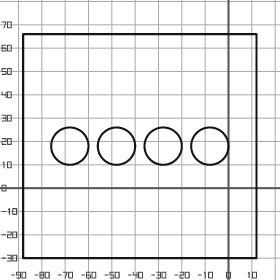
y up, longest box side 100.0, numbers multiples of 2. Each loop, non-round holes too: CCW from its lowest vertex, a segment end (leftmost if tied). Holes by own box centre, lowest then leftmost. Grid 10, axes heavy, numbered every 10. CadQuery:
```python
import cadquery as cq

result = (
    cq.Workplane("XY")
    .moveTo(-88.0, -30.0)
    .lineTo(12.0, -30.0)
    .lineTo(12.0, 66.0)
    .lineTo(-88.0, 66.0)
    .close()
    .moveTo(-68.0, 18.0)
    .circle(8.0)
    .moveTo(-48.0, 18.0)
    .circle(8.0)
    .moveTo(-28.0, 18.0)
    .circle(8.0)
    .moveTo(-8.0, 18.0)
    .circle(8.0)
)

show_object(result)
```